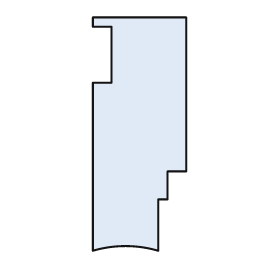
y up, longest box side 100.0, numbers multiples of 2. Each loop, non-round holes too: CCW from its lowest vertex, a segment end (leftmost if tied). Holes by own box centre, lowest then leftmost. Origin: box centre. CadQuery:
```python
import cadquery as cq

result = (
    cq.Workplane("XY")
    .moveTo(-20.0, -50.0)
    .threePointArc((-6.0, -48.0), (8.0, -50.0))
    .lineTo(8.0, -28.0)
    .lineTo(12.0, -28.0)
    .lineTo(12.0, -16.0)
    .lineTo(20.0, -16.0)
    .lineTo(20.0, 50.0)
    .lineTo(-20.0, 50.0)
    .lineTo(-20.0, 46.0)
    .lineTo(-12.0, 46.0)
    .lineTo(-12.0, 22.0)
    .lineTo(-20.0, 22.0)
    .close()
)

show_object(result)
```